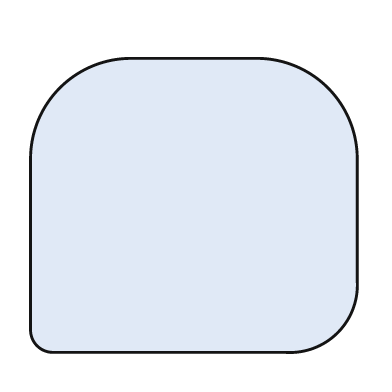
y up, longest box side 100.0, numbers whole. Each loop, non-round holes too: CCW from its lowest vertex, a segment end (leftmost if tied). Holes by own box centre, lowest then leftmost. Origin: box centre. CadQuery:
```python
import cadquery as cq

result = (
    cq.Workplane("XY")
    .moveTo(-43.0, -45.0)
    .lineTo(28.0, -45.0)
    .threePointArc((44.0, -39.0), (50.0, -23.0))
    .lineTo(50.0, 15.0)
    .threePointArc((41.0, 36.0), (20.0, 45.0))
    .lineTo(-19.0, 45.0)
    .threePointArc((-41.0, 36.0), (-50.0, 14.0))
    .lineTo(-50.0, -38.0)
    .threePointArc((-48.0, -43.0), (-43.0, -45.0))
    .close()
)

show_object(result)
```